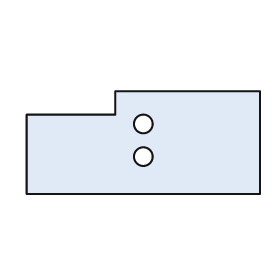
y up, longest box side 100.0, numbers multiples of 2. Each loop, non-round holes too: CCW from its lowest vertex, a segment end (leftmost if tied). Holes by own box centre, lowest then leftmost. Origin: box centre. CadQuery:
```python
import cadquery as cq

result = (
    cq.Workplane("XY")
    .moveTo(-50.0, -22.0)
    .lineTo(50.0, -22.0)
    .lineTo(50.0, 22.0)
    .lineTo(-12.0, 22.0)
    .lineTo(-12.0, 12.0)
    .lineTo(-50.0, 12.0)
    .close()
    .moveTo(0.0, -6.0)
    .circle(4.0)
    .moveTo(0.0, 8.0)
    .circle(4.0)
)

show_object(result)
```